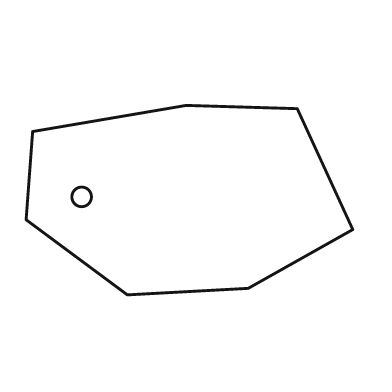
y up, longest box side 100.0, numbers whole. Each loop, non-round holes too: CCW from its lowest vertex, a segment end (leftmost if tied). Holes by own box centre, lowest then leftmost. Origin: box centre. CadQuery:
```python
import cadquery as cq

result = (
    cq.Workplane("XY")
    .moveTo(-19.0, -29.0)
    .lineTo(18.0, -27.0)
    .lineTo(50.0, -9.0)
    .lineTo(33.0, 28.0)
    .lineTo(-1.0, 29.0)
    .lineTo(-48.0, 21.0)
    .lineTo(-50.0, -6.0)
    .close()
    .moveTo(-33.0, 1.0)
    .circle(3.0)
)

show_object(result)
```